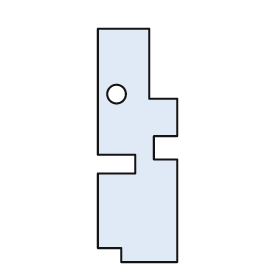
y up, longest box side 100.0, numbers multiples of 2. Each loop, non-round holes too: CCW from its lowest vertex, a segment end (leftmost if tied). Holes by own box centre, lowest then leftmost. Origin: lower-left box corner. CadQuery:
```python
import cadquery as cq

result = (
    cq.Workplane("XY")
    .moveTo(10.0, 0.0)
    .lineTo(34.0, 0.0)
    .lineTo(34.0, 44.0)
    .lineTo(24.0, 44.0)
    .lineTo(24.0, 54.0)
    .lineTo(34.0, 54.0)
    .lineTo(34.0, 70.0)
    .lineTo(22.0, 70.0)
    .lineTo(22.0, 100.0)
    .lineTo(0.0, 100.0)
    .lineTo(0.0, 46.0)
    .lineTo(16.0, 46.0)
    .lineTo(16.0, 38.0)
    .lineTo(0.0, 38.0)
    .lineTo(0.0, 6.0)
    .lineTo(10.0, 6.0)
    .close()
    .moveTo(8.0, 72.0)
    .circle(4.0)
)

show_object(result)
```